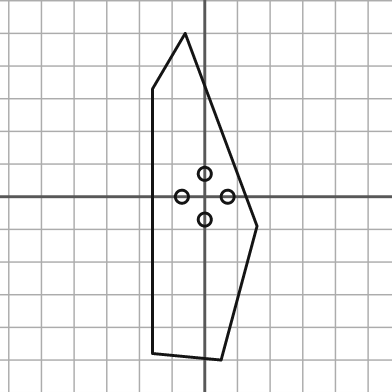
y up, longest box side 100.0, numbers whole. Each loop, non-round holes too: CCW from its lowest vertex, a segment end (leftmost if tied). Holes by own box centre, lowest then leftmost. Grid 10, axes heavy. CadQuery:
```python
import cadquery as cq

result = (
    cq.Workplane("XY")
    .moveTo(5.0, -50.0)
    .lineTo(16.0, -9.0)
    .lineTo(-6.0, 50.0)
    .lineTo(-16.0, 33.0)
    .lineTo(-16.0, -48.0)
    .close()
    .moveTo(0.0, -7.0)
    .circle(2.0)
    .moveTo(-7.0, 0.0)
    .circle(2.0)
    .moveTo(7.0, 0.0)
    .circle(2.0)
    .moveTo(0.0, 7.0)
    .circle(2.0)
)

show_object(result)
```